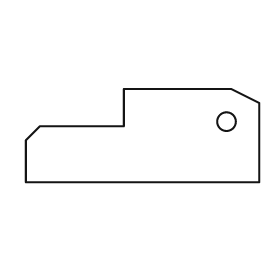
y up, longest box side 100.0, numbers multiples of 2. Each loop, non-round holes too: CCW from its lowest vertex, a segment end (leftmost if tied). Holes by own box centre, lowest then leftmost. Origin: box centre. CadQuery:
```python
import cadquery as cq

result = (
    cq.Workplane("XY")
    .moveTo(-50.0, -20.0)
    .lineTo(50.0, -20.0)
    .lineTo(50.0, 14.0)
    .lineTo(38.0, 20.0)
    .lineTo(-8.0, 20.0)
    .lineTo(-8.0, 4.0)
    .lineTo(-44.0, 4.0)
    .lineTo(-50.0, -2.0)
    .close()
    .moveTo(36.0, 6.0)
    .circle(4.0)
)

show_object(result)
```